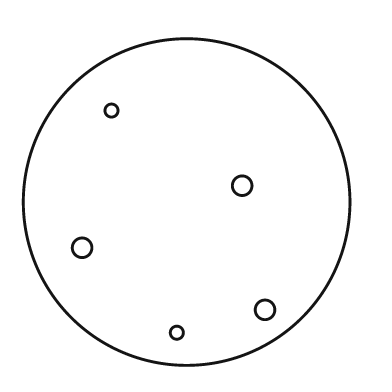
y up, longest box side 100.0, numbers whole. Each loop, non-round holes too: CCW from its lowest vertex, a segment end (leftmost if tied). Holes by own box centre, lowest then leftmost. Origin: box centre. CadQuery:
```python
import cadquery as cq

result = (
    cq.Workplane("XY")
    .moveTo(0.0, 0.0)
    .circle(50.0)
    .moveTo(-3.0, -40.0)
    .circle(2.0)
    .moveTo(24.0, -33.0)
    .circle(3.0)
    .moveTo(-32.0, -14.0)
    .circle(3.0)
    .moveTo(17.0, 5.0)
    .circle(3.0)
    .moveTo(-23.0, 28.0)
    .circle(2.0)
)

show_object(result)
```